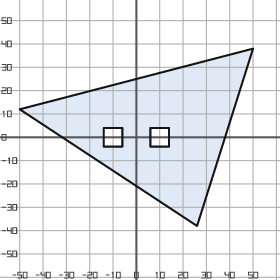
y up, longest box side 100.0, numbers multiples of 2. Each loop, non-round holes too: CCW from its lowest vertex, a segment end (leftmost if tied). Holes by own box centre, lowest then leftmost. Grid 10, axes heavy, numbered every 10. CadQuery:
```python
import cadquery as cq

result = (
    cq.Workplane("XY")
    .moveTo(26.0, -38.0)
    .lineTo(50.0, 38.0)
    .lineTo(-50.0, 12.0)
    .close()
    .moveTo(-14.0, -4.0)
    .lineTo(-6.0, -4.0)
    .lineTo(-6.0, 4.0)
    .lineTo(-14.0, 4.0)
    .close()
    .moveTo(6.0, -4.0)
    .lineTo(14.0, -4.0)
    .lineTo(14.0, 4.0)
    .lineTo(6.0, 4.0)
    .close()
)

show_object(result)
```